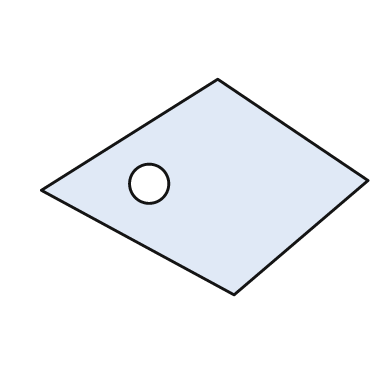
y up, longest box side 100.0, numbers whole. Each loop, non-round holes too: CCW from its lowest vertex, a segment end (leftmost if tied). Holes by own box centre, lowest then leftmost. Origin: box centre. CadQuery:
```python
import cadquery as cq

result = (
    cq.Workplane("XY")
    .moveTo(9.0, -33.0)
    .lineTo(50.0, 2.0)
    .lineTo(4.0, 33.0)
    .lineTo(-50.0, -1.0)
    .close()
    .moveTo(-17.0, 1.0)
    .circle(6.0)
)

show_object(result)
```